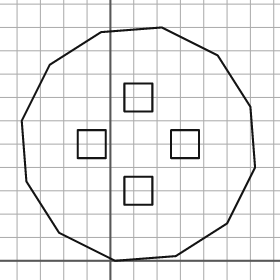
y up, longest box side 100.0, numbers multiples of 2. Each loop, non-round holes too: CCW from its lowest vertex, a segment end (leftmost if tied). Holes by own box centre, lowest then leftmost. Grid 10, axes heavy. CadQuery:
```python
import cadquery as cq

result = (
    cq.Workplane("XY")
    .moveTo(2.0, 0.0)
    .lineTo(28.0, 2.0)
    .lineTo(50.0, 16.0)
    .lineTo(62.0, 40.0)
    .lineTo(60.0, 66.0)
    .lineTo(46.0, 88.0)
    .lineTo(22.0, 100.0)
    .lineTo(-4.0, 98.0)
    .lineTo(-26.0, 84.0)
    .lineTo(-38.0, 60.0)
    .lineTo(-36.0, 34.0)
    .lineTo(-22.0, 12.0)
    .close()
    .moveTo(6.0, 24.0)
    .lineTo(18.0, 24.0)
    .lineTo(18.0, 36.0)
    .lineTo(6.0, 36.0)
    .close()
    .moveTo(-14.0, 44.0)
    .lineTo(-2.0, 44.0)
    .lineTo(-2.0, 56.0)
    .lineTo(-14.0, 56.0)
    .close()
    .moveTo(26.0, 44.0)
    .lineTo(38.0, 44.0)
    .lineTo(38.0, 56.0)
    .lineTo(26.0, 56.0)
    .close()
    .moveTo(6.0, 64.0)
    .lineTo(18.0, 64.0)
    .lineTo(18.0, 76.0)
    .lineTo(6.0, 76.0)
    .close()
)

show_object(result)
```